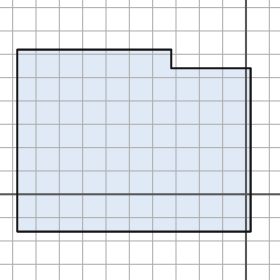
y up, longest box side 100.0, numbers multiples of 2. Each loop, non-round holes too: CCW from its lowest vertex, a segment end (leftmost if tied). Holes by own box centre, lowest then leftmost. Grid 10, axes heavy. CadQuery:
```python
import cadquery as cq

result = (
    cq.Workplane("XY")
    .moveTo(-98.0, -16.0)
    .lineTo(2.0, -16.0)
    .lineTo(2.0, 54.0)
    .lineTo(-32.0, 54.0)
    .lineTo(-32.0, 62.0)
    .lineTo(-98.0, 62.0)
    .close()
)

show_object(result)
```